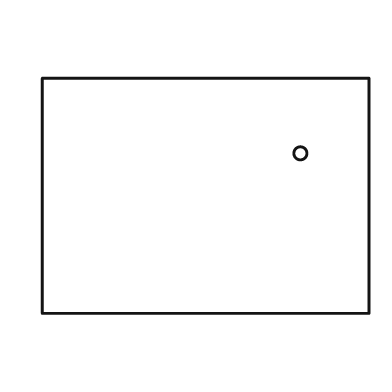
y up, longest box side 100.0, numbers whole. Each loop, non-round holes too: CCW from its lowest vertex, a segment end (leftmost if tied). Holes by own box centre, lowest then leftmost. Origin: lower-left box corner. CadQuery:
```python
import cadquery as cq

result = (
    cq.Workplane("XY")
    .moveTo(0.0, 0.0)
    .lineTo(100.0, 0.0)
    .lineTo(100.0, 72.0)
    .lineTo(0.0, 72.0)
    .close()
    .moveTo(79.0, 49.0)
    .circle(2.0)
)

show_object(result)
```